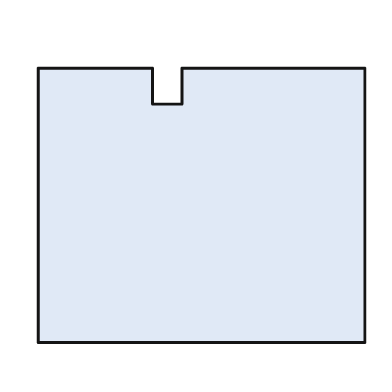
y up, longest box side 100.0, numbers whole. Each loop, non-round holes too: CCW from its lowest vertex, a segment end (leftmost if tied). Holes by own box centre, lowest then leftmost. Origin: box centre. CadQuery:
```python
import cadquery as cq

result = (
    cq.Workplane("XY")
    .moveTo(-50.0, -42.0)
    .lineTo(50.0, -42.0)
    .lineTo(50.0, 42.0)
    .lineTo(-6.0, 42.0)
    .lineTo(-6.0, 31.0)
    .lineTo(-15.0, 31.0)
    .lineTo(-15.0, 42.0)
    .lineTo(-50.0, 42.0)
    .close()
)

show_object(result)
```